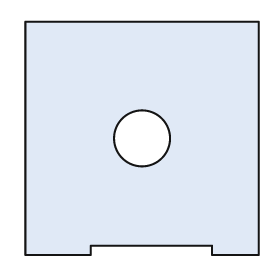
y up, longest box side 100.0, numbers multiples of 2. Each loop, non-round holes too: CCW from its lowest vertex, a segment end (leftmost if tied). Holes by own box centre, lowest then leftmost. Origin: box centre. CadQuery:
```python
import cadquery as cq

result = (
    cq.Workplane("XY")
    .moveTo(-50.0, -50.0)
    .lineTo(-22.0, -50.0)
    .lineTo(-22.0, -46.0)
    .lineTo(30.0, -46.0)
    .lineTo(30.0, -50.0)
    .lineTo(50.0, -50.0)
    .lineTo(50.0, 50.0)
    .lineTo(-50.0, 50.0)
    .close()
    .moveTo(0.0, 0.0)
    .circle(12.0)
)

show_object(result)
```